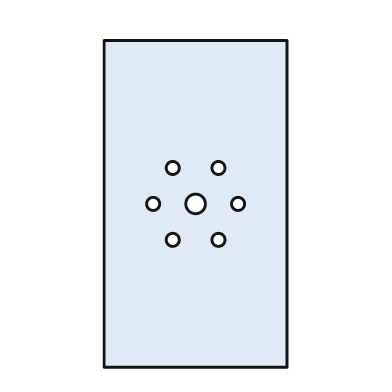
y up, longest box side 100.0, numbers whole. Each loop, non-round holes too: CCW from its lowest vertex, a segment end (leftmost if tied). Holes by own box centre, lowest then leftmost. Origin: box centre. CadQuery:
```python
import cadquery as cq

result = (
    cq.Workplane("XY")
    .moveTo(-28.0, -50.0)
    .lineTo(28.0, -50.0)
    .lineTo(28.0, 50.0)
    .lineTo(-28.0, 50.0)
    .close()
    .moveTo(-7.0, -11.0)
    .circle(2.0)
    .moveTo(7.0, -11.0)
    .circle(2.0)
    .moveTo(-13.0, 0.0)
    .circle(2.0)
    .moveTo(0.0, 0.0)
    .circle(3.0)
    .moveTo(13.0, 0.0)
    .circle(2.0)
    .moveTo(-7.0, 11.0)
    .circle(2.0)
    .moveTo(7.0, 11.0)
    .circle(2.0)
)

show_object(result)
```